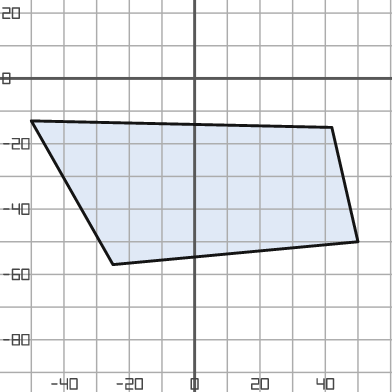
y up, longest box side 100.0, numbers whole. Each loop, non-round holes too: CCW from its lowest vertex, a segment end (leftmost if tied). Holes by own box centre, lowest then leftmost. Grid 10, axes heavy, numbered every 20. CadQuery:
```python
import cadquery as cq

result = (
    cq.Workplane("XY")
    .moveTo(-25.0, -57.0)
    .lineTo(50.0, -50.0)
    .lineTo(42.0, -15.0)
    .lineTo(-50.0, -13.0)
    .close()
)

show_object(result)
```